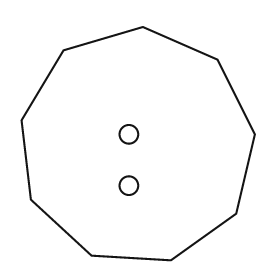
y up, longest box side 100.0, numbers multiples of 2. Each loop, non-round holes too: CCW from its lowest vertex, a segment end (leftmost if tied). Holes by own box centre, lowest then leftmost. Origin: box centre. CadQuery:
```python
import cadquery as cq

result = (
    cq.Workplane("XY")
    .moveTo(14.0, -50.0)
    .lineTo(42.0, -30.0)
    .lineTo(50.0, 4.0)
    .lineTo(34.0, 36.0)
    .lineTo(2.0, 50.0)
    .lineTo(-32.0, 40.0)
    .lineTo(-50.0, 10.0)
    .lineTo(-46.0, -24.0)
    .lineTo(-20.0, -48.0)
    .close()
    .moveTo(-4.0, -18.0)
    .circle(4.0)
    .moveTo(-4.0, 4.0)
    .circle(4.0)
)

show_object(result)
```